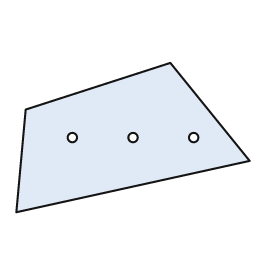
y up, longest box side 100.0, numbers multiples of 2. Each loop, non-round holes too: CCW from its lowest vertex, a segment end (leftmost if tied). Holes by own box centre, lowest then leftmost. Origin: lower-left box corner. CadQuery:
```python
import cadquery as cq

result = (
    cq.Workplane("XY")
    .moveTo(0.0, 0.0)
    .lineTo(100.0, 22.0)
    .lineTo(66.0, 64.0)
    .lineTo(4.0, 44.0)
    .close()
    .moveTo(24.0, 32.0)
    .circle(2.0)
    .moveTo(50.0, 32.0)
    .circle(2.0)
    .moveTo(76.0, 32.0)
    .circle(2.0)
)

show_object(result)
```